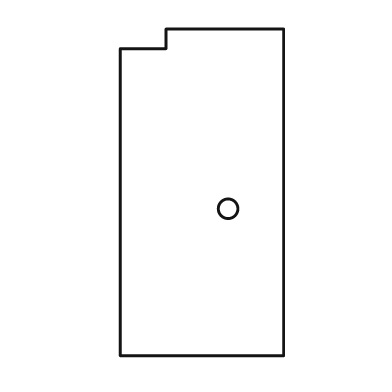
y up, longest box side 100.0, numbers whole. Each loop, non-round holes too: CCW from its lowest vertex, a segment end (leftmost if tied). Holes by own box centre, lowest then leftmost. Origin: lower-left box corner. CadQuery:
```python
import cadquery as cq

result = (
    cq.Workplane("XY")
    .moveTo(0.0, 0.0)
    .lineTo(50.0, 0.0)
    .lineTo(50.0, 100.0)
    .lineTo(14.0, 100.0)
    .lineTo(14.0, 94.0)
    .lineTo(0.0, 94.0)
    .close()
    .moveTo(33.0, 45.0)
    .circle(3.0)
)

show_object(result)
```